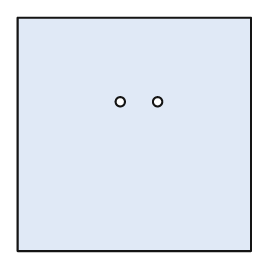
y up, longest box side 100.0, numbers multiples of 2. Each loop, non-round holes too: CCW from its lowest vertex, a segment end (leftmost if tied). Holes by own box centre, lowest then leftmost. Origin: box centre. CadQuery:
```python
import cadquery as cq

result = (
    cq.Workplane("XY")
    .moveTo(-50.0, -50.0)
    .lineTo(50.0, -50.0)
    .lineTo(50.0, 50.0)
    .lineTo(-50.0, 50.0)
    .close()
    .moveTo(-6.0, 14.0)
    .circle(2.0)
    .moveTo(10.0, 14.0)
    .circle(2.0)
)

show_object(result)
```